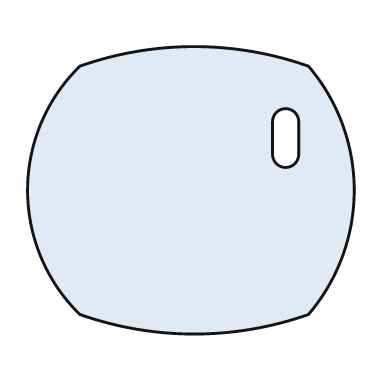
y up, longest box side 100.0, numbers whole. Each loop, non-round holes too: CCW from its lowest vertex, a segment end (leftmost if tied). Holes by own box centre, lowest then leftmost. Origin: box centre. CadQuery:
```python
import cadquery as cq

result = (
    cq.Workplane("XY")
    .moveTo(-34.0, -38.0)
    .threePointArc((1.0, -44.0), (36.0, -38.0))
    .threePointArc((50.0, 0.0), (36.0, 38.0))
    .threePointArc((1.0, 44.0), (-34.0, 38.0))
    .threePointArc((-50.0, 0.0), (-34.0, -38.0))
    .close()
    .moveTo(25.0, 11.0)
    .threePointArc((29.0, 7.0), (33.0, 11.0))
    .lineTo(33.0, 21.0)
    .threePointArc((29.0, 25.0), (25.0, 21.0))
    .close()
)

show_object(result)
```